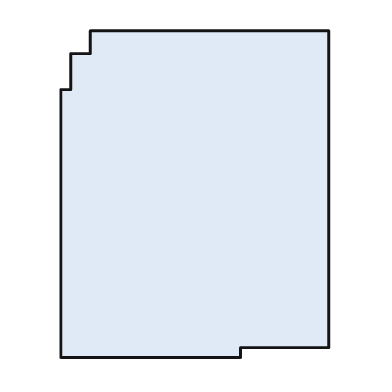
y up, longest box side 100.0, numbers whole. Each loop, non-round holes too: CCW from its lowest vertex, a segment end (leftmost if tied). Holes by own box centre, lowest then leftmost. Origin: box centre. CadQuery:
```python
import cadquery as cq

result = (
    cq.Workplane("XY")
    .moveTo(-41.0, -50.0)
    .lineTo(14.0, -50.0)
    .lineTo(14.0, -47.0)
    .lineTo(41.0, -47.0)
    .lineTo(41.0, 50.0)
    .lineTo(-32.0, 50.0)
    .lineTo(-32.0, 43.0)
    .lineTo(-38.0, 43.0)
    .lineTo(-38.0, 32.0)
    .lineTo(-41.0, 32.0)
    .close()
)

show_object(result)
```